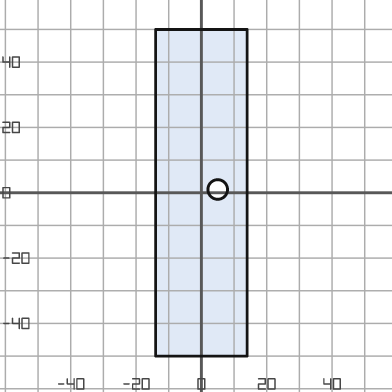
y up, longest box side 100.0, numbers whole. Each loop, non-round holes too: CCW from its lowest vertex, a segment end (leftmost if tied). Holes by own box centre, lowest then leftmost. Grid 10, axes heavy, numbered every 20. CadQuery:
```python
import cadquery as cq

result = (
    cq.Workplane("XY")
    .moveTo(-14.0, -50.0)
    .lineTo(14.0, -50.0)
    .lineTo(14.0, 50.0)
    .lineTo(-14.0, 50.0)
    .close()
    .moveTo(5.0, 1.0)
    .circle(3.0)
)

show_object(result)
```